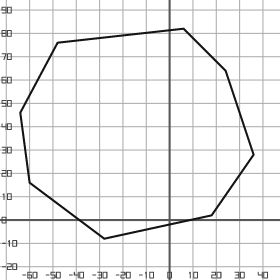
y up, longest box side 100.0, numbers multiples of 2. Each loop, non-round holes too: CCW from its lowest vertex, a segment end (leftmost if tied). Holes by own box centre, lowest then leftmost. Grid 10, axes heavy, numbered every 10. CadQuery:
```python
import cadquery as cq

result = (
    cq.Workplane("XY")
    .moveTo(-28.0, -8.0)
    .lineTo(18.0, 2.0)
    .lineTo(36.0, 28.0)
    .lineTo(24.0, 64.0)
    .lineTo(6.0, 82.0)
    .lineTo(-48.0, 76.0)
    .lineTo(-64.0, 46.0)
    .lineTo(-60.0, 16.0)
    .close()
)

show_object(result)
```